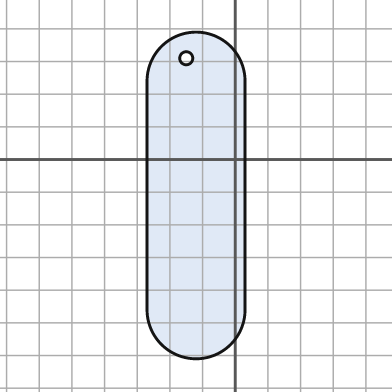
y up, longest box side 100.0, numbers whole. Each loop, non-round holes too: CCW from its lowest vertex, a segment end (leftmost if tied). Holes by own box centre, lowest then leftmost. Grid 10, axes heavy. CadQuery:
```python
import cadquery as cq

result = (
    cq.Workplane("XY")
    .moveTo(-27.0, -46.0)
    .threePointArc((-12.0, -61.0), (3.0, -46.0))
    .lineTo(3.0, 24.0)
    .threePointArc((-12.0, 39.0), (-27.0, 24.0))
    .close()
    .moveTo(-15.0, 31.0)
    .circle(2.0)
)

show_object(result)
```